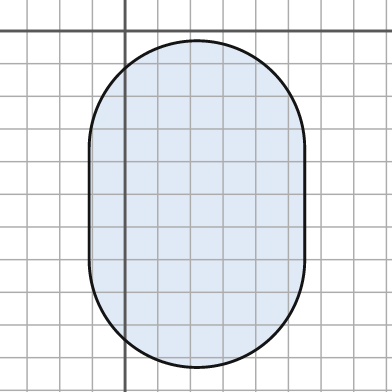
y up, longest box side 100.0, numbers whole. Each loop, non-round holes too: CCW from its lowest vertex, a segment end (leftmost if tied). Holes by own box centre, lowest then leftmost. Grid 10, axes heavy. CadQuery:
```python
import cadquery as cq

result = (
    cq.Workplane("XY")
    .moveTo(-11.0, -70.0)
    .threePointArc((22.0, -103.0), (55.0, -70.0))
    .lineTo(55.0, -36.0)
    .threePointArc((22.0, -3.0), (-11.0, -36.0))
    .close()
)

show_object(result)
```